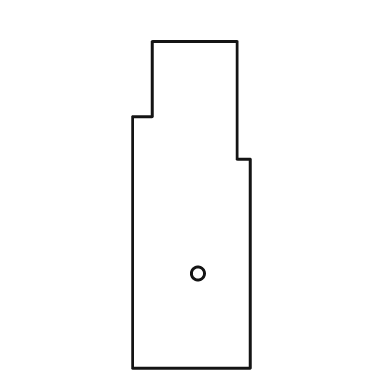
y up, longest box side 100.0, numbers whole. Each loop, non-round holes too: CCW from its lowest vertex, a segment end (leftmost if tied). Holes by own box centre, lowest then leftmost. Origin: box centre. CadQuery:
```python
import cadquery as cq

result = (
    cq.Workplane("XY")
    .moveTo(-18.0, -50.0)
    .lineTo(18.0, -50.0)
    .lineTo(18.0, 14.0)
    .lineTo(14.0, 14.0)
    .lineTo(14.0, 50.0)
    .lineTo(-12.0, 50.0)
    .lineTo(-12.0, 27.0)
    .lineTo(-18.0, 27.0)
    .close()
    .moveTo(2.0, -21.0)
    .circle(2.0)
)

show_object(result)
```